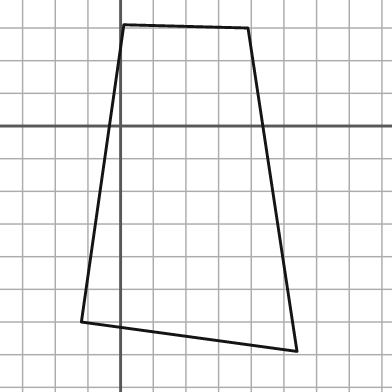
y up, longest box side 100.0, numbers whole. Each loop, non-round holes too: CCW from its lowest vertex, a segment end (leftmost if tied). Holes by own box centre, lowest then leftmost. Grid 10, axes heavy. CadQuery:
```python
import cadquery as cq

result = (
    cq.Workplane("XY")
    .moveTo(54.0, -69.0)
    .lineTo(39.0, 30.0)
    .lineTo(1.0, 31.0)
    .lineTo(-12.0, -60.0)
    .close()
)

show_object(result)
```